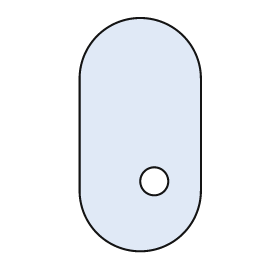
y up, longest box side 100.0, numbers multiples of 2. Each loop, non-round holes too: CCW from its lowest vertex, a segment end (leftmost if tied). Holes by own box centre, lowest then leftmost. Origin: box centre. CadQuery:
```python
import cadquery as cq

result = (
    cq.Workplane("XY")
    .moveTo(-26.0, -24.0)
    .threePointArc((0.0, -50.0), (26.0, -24.0))
    .lineTo(26.0, 24.0)
    .threePointArc((0.0, 50.0), (-26.0, 24.0))
    .close()
    .moveTo(6.0, -20.0)
    .circle(6.0)
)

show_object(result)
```